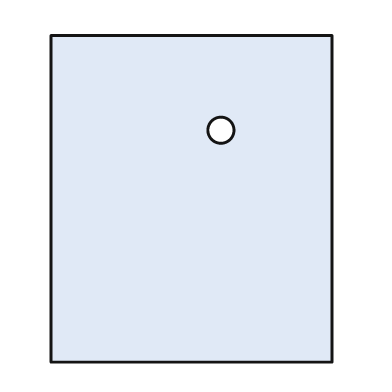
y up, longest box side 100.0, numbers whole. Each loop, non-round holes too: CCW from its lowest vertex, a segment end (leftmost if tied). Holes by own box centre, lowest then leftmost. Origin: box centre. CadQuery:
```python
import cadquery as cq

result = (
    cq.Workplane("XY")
    .moveTo(-43.0, -50.0)
    .lineTo(43.0, -50.0)
    .lineTo(43.0, 50.0)
    .lineTo(-43.0, 50.0)
    .close()
    .moveTo(9.0, 21.0)
    .circle(4.0)
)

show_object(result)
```